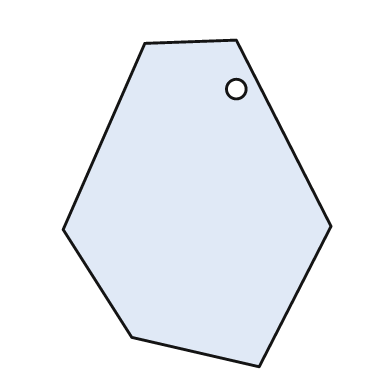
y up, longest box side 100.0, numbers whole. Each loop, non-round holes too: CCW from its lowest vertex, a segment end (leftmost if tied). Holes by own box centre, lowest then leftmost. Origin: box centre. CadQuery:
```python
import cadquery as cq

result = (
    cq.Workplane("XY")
    .moveTo(19.0, -50.0)
    .lineTo(41.0, -7.0)
    .lineTo(12.0, 50.0)
    .lineTo(-16.0, 49.0)
    .lineTo(-41.0, -8.0)
    .lineTo(-20.0, -41.0)
    .close()
    .moveTo(12.0, 35.0)
    .circle(3.0)
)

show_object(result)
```